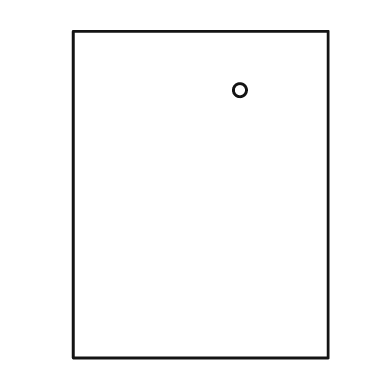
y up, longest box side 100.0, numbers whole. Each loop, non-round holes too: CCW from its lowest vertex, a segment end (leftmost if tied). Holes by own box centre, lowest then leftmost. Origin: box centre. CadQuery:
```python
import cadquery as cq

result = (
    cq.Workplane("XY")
    .moveTo(-39.0, -50.0)
    .lineTo(39.0, -50.0)
    .lineTo(39.0, 50.0)
    .lineTo(-39.0, 50.0)
    .close()
    .moveTo(12.0, 32.0)
    .circle(2.0)
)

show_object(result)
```